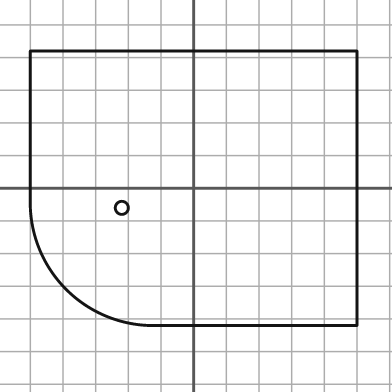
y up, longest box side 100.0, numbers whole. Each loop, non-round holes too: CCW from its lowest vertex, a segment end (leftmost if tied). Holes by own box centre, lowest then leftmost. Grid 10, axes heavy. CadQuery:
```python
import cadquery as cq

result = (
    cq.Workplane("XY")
    .moveTo(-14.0, -42.0)
    .lineTo(50.0, -42.0)
    .lineTo(50.0, 42.0)
    .lineTo(-50.0, 42.0)
    .lineTo(-50.0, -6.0)
    .threePointArc((-39.0, -31.0), (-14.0, -42.0))
    .close()
    .moveTo(-22.0, -6.0)
    .circle(2.0)
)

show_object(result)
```